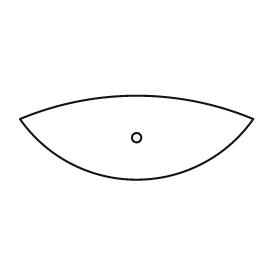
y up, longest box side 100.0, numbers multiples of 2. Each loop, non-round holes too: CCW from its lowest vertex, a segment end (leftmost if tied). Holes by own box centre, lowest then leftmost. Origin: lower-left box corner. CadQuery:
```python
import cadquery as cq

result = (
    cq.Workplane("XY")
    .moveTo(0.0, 26.0)
    .threePointArc((50.0, 0.0), (100.0, 26.0))
    .threePointArc((50.0, 36.0), (0.0, 26.0))
    .close()
    .moveTo(50.0, 18.0)
    .circle(2.0)
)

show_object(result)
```